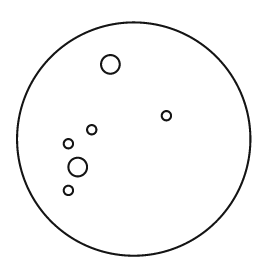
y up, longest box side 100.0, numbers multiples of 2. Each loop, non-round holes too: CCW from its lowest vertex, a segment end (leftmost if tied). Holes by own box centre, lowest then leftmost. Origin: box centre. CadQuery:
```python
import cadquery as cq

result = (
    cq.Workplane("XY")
    .moveTo(0.0, 0.0)
    .circle(50.0)
    .moveTo(-28.0, -22.0)
    .circle(2.0)
    .moveTo(-24.0, -12.0)
    .circle(4.0)
    .moveTo(-28.0, -2.0)
    .circle(2.0)
    .moveTo(-18.0, 4.0)
    .circle(2.0)
    .moveTo(14.0, 10.0)
    .circle(2.0)
    .moveTo(-10.0, 32.0)
    .circle(4.0)
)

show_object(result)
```